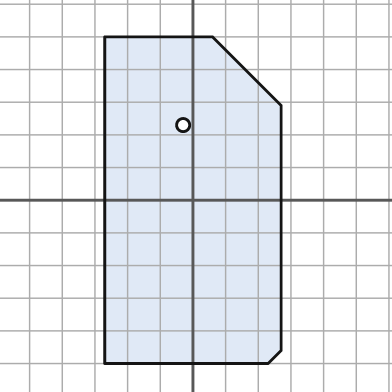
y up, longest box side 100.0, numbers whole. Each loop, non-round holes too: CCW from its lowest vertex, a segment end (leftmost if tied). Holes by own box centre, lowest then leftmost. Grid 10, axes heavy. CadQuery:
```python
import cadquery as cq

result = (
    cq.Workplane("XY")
    .moveTo(-27.0, -50.0)
    .lineTo(23.0, -50.0)
    .lineTo(27.0, -46.0)
    .lineTo(27.0, 29.0)
    .lineTo(6.0, 50.0)
    .lineTo(-27.0, 50.0)
    .close()
    .moveTo(-3.0, 23.0)
    .circle(2.0)
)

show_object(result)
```